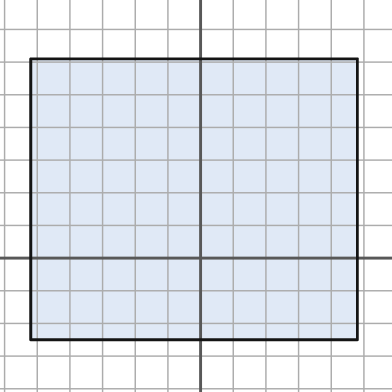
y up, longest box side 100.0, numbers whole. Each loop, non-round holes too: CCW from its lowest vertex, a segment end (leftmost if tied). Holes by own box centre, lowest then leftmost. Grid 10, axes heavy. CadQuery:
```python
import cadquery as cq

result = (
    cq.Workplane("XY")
    .moveTo(-52.0, -25.0)
    .lineTo(48.0, -25.0)
    .lineTo(48.0, 61.0)
    .lineTo(-52.0, 61.0)
    .close()
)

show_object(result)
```